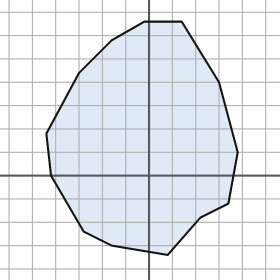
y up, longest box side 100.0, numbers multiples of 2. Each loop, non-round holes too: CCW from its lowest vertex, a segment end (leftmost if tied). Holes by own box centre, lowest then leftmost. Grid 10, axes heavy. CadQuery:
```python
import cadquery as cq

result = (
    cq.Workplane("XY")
    .moveTo(8.0, -34.0)
    .lineTo(22.0, -18.0)
    .lineTo(34.0, -12.0)
    .lineTo(38.0, 10.0)
    .lineTo(30.0, 40.0)
    .lineTo(14.0, 66.0)
    .lineTo(-2.0, 66.0)
    .lineTo(-16.0, 58.0)
    .lineTo(-30.0, 44.0)
    .lineTo(-44.0, 18.0)
    .lineTo(-42.0, 0.0)
    .lineTo(-28.0, -24.0)
    .lineTo(-16.0, -30.0)
    .close()
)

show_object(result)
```